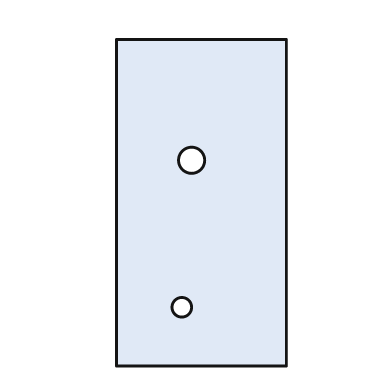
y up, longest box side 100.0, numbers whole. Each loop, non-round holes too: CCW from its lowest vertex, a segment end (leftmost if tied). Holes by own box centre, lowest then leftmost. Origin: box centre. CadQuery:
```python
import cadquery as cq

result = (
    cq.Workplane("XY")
    .moveTo(-26.0, -50.0)
    .lineTo(26.0, -50.0)
    .lineTo(26.0, 50.0)
    .lineTo(-26.0, 50.0)
    .close()
    .moveTo(-6.0, -32.0)
    .circle(3.0)
    .moveTo(-3.0, 13.0)
    .circle(4.0)
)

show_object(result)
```